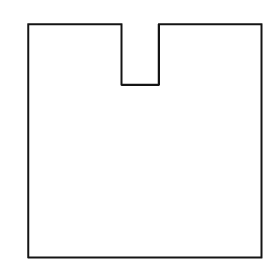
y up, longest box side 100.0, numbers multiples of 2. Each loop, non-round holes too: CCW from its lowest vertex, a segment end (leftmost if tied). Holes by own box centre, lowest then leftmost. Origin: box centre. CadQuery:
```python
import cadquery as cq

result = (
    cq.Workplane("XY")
    .moveTo(-50.0, -50.0)
    .lineTo(50.0, -50.0)
    .lineTo(50.0, 50.0)
    .lineTo(6.0, 50.0)
    .lineTo(6.0, 24.0)
    .lineTo(-10.0, 24.0)
    .lineTo(-10.0, 50.0)
    .lineTo(-50.0, 50.0)
    .close()
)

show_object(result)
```